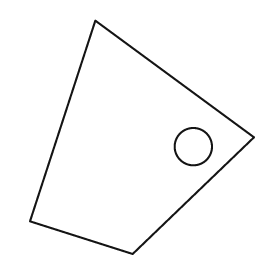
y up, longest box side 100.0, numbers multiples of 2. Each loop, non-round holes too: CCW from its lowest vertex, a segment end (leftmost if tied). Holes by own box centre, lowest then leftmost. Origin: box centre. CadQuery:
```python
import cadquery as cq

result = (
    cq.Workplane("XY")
    .moveTo(-4.0, -50.0)
    .lineTo(48.0, 0.0)
    .lineTo(-20.0, 50.0)
    .lineTo(-48.0, -36.0)
    .close()
    .moveTo(22.0, -4.0)
    .circle(8.0)
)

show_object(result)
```